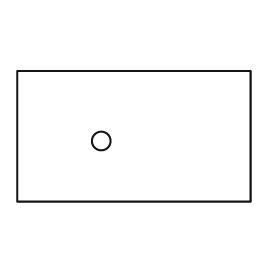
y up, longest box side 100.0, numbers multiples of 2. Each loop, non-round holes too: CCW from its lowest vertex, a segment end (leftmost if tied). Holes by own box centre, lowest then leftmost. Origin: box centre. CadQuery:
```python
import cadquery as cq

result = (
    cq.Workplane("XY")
    .moveTo(-50.0, -28.0)
    .lineTo(50.0, -28.0)
    .lineTo(50.0, 28.0)
    .lineTo(-50.0, 28.0)
    .close()
    .moveTo(-14.0, -2.0)
    .circle(4.0)
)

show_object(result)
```